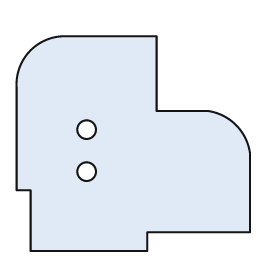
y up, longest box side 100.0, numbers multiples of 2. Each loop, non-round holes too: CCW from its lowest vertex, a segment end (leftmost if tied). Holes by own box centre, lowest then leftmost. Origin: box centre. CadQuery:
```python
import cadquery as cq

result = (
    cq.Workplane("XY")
    .moveTo(-44.0, -46.0)
    .lineTo(6.0, -46.0)
    .lineTo(6.0, -38.0)
    .lineTo(50.0, -38.0)
    .lineTo(50.0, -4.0)
    .threePointArc((44.0, 8.0), (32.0, 14.0))
    .lineTo(10.0, 14.0)
    .lineTo(10.0, 46.0)
    .lineTo(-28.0, 46.0)
    .threePointArc((-44.0, 40.0), (-50.0, 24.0))
    .lineTo(-50.0, -20.0)
    .lineTo(-44.0, -20.0)
    .close()
    .moveTo(-20.0, -12.0)
    .circle(4.0)
    .moveTo(-20.0, 6.0)
    .circle(4.0)
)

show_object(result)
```